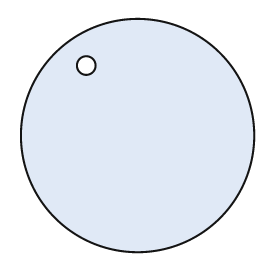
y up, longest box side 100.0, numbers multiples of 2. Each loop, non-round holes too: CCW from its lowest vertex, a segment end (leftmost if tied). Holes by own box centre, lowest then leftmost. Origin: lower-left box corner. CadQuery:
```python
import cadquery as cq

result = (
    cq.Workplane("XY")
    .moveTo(50.0, 50.0)
    .circle(50.0)
    .moveTo(28.0, 80.0)
    .circle(4.0)
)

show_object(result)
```